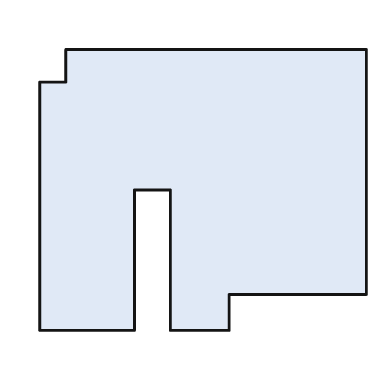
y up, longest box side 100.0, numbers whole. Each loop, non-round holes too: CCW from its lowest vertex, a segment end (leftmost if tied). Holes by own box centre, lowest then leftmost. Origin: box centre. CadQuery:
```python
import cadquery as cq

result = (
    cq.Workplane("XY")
    .moveTo(-50.0, -43.0)
    .lineTo(-21.0, -43.0)
    .lineTo(-21.0, 0.0)
    .lineTo(-10.0, 0.0)
    .lineTo(-10.0, -43.0)
    .lineTo(8.0, -43.0)
    .lineTo(8.0, -32.0)
    .lineTo(50.0, -32.0)
    .lineTo(50.0, 43.0)
    .lineTo(-42.0, 43.0)
    .lineTo(-42.0, 33.0)
    .lineTo(-50.0, 33.0)
    .close()
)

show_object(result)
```